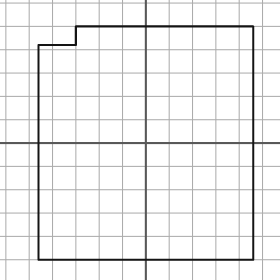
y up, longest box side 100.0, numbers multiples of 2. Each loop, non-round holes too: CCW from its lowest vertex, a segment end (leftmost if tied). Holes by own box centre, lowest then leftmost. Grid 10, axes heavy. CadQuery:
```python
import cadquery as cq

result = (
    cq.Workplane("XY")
    .moveTo(-46.0, -50.0)
    .lineTo(46.0, -50.0)
    .lineTo(46.0, 50.0)
    .lineTo(-30.0, 50.0)
    .lineTo(-30.0, 42.0)
    .lineTo(-46.0, 42.0)
    .close()
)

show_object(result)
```